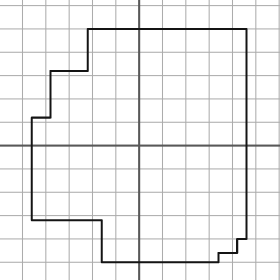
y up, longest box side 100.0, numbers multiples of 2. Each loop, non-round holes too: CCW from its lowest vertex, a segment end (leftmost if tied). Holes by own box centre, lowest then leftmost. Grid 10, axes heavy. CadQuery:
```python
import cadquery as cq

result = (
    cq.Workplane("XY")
    .moveTo(-16.0, -50.0)
    .lineTo(34.0, -50.0)
    .lineTo(34.0, -46.0)
    .lineTo(42.0, -46.0)
    .lineTo(42.0, -40.0)
    .lineTo(46.0, -40.0)
    .lineTo(46.0, 50.0)
    .lineTo(-22.0, 50.0)
    .lineTo(-22.0, 32.0)
    .lineTo(-38.0, 32.0)
    .lineTo(-38.0, 12.0)
    .lineTo(-46.0, 12.0)
    .lineTo(-46.0, -32.0)
    .lineTo(-16.0, -32.0)
    .close()
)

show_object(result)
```